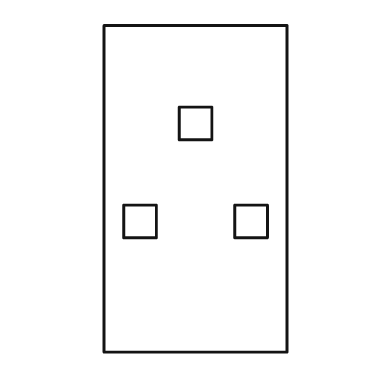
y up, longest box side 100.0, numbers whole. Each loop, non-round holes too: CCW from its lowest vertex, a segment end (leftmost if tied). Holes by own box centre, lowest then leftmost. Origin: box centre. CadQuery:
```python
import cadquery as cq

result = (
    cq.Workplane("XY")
    .moveTo(-28.0, -50.0)
    .lineTo(28.0, -50.0)
    .lineTo(28.0, 50.0)
    .lineTo(-28.0, 50.0)
    .close()
    .moveTo(-22.0, -15.0)
    .lineTo(-12.0, -15.0)
    .lineTo(-12.0, -5.0)
    .lineTo(-22.0, -5.0)
    .close()
    .moveTo(12.0, -15.0)
    .lineTo(22.0, -15.0)
    .lineTo(22.0, -5.0)
    .lineTo(12.0, -5.0)
    .close()
    .moveTo(-5.0, 15.0)
    .lineTo(5.0, 15.0)
    .lineTo(5.0, 25.0)
    .lineTo(-5.0, 25.0)
    .close()
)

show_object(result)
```